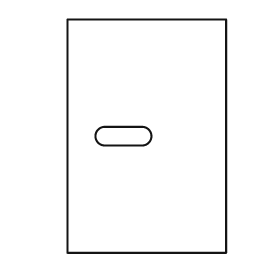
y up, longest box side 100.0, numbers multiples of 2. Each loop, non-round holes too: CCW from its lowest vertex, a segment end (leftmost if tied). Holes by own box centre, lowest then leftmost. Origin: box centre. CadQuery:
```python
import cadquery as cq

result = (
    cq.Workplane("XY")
    .moveTo(-34.0, -50.0)
    .lineTo(34.0, -50.0)
    .lineTo(34.0, 50.0)
    .lineTo(-34.0, 50.0)
    .close()
    .moveTo(-18.0, -4.0)
    .lineTo(-2.0, -4.0)
    .threePointArc((2.0, 0.0), (-2.0, 4.0))
    .lineTo(-18.0, 4.0)
    .threePointArc((-22.0, 0.0), (-18.0, -4.0))
    .close()
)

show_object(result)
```